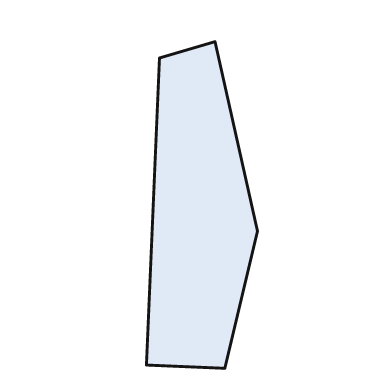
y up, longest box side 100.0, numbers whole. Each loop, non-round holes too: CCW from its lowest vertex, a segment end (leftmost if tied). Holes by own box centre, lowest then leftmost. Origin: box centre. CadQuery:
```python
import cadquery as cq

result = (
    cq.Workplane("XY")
    .moveTo(7.0, -50.0)
    .lineTo(17.0, -8.0)
    .lineTo(4.0, 50.0)
    .lineTo(-13.0, 45.0)
    .lineTo(-17.0, -49.0)
    .close()
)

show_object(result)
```